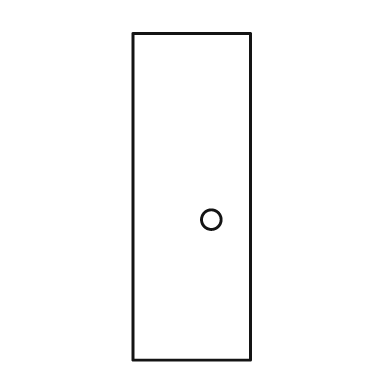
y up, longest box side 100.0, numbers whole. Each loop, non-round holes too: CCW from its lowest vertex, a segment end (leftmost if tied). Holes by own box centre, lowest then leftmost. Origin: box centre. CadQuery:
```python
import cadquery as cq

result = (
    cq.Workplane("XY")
    .moveTo(-18.0, -50.0)
    .lineTo(18.0, -50.0)
    .lineTo(18.0, 50.0)
    .lineTo(-18.0, 50.0)
    .close()
    .moveTo(6.0, -7.0)
    .circle(3.0)
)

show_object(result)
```